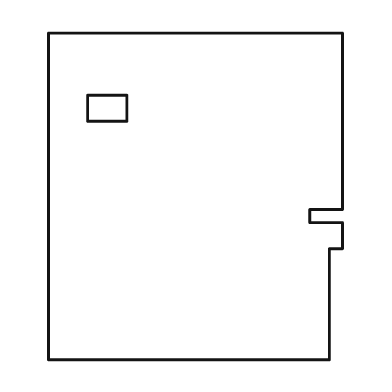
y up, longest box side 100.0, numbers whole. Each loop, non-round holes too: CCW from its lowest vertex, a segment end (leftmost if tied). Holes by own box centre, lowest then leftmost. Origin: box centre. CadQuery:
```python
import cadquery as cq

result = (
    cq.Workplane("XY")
    .moveTo(-45.0, -50.0)
    .lineTo(41.0, -50.0)
    .lineTo(41.0, -16.0)
    .lineTo(45.0, -16.0)
    .lineTo(45.0, -8.0)
    .lineTo(35.0, -8.0)
    .lineTo(35.0, -4.0)
    .lineTo(45.0, -4.0)
    .lineTo(45.0, 50.0)
    .lineTo(-45.0, 50.0)
    .close()
    .moveTo(-33.0, 23.0)
    .lineTo(-21.0, 23.0)
    .lineTo(-21.0, 31.0)
    .lineTo(-33.0, 31.0)
    .close()
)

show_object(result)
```